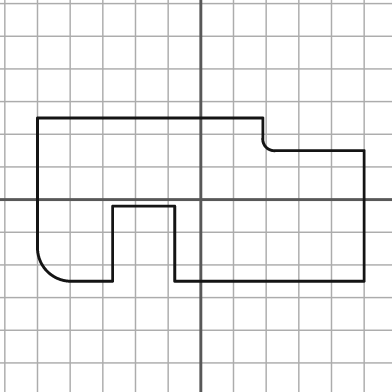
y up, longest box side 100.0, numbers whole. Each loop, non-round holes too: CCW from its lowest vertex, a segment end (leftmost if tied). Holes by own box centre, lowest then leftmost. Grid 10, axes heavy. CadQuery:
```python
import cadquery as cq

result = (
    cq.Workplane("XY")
    .moveTo(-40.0, -25.0)
    .lineTo(-27.0, -25.0)
    .lineTo(-27.0, -2.0)
    .lineTo(-8.0, -2.0)
    .lineTo(-8.0, -25.0)
    .lineTo(50.0, -25.0)
    .lineTo(50.0, 15.0)
    .lineTo(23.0, 15.0)
    .threePointArc((20.0, 16.0), (19.0, 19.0))
    .lineTo(19.0, 25.0)
    .lineTo(-50.0, 25.0)
    .lineTo(-50.0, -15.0)
    .threePointArc((-47.0, -22.0), (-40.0, -25.0))
    .close()
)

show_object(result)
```